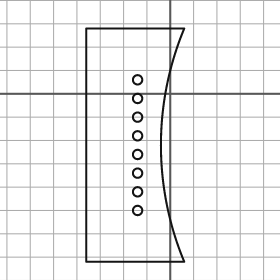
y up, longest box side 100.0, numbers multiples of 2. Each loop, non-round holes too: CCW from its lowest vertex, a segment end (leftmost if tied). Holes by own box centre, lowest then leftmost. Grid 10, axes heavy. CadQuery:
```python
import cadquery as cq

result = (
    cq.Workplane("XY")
    .moveTo(-36.0, -72.0)
    .lineTo(6.0, -72.0)
    .threePointArc((-4.0, -22.0), (6.0, 28.0))
    .lineTo(-36.0, 28.0)
    .close()
    .moveTo(-14.0, -50.0)
    .circle(2.0)
    .moveTo(-14.0, -42.0)
    .circle(2.0)
    .moveTo(-14.0, -34.0)
    .circle(2.0)
    .moveTo(-14.0, -26.0)
    .circle(2.0)
    .moveTo(-14.0, -18.0)
    .circle(2.0)
    .moveTo(-14.0, -10.0)
    .circle(2.0)
    .moveTo(-14.0, -2.0)
    .circle(2.0)
    .moveTo(-14.0, 6.0)
    .circle(2.0)
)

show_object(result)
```